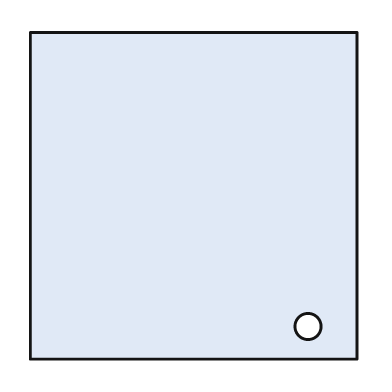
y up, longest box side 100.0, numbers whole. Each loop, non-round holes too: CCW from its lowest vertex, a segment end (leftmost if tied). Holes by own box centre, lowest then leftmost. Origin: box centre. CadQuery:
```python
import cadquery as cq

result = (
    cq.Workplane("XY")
    .moveTo(-50.0, -50.0)
    .lineTo(50.0, -50.0)
    .lineTo(50.0, 50.0)
    .lineTo(-50.0, 50.0)
    .close()
    .moveTo(35.0, -40.0)
    .circle(4.0)
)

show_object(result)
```